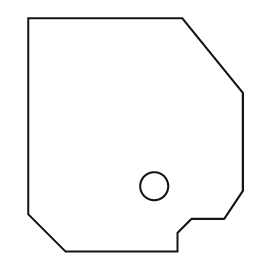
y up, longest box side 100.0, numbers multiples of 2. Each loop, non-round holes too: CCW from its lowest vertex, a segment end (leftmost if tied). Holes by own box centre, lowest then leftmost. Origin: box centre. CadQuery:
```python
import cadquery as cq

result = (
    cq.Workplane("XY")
    .moveTo(-30.0, -50.0)
    .lineTo(18.0, -50.0)
    .lineTo(18.0, -42.0)
    .lineTo(24.0, -36.0)
    .lineTo(38.0, -36.0)
    .lineTo(46.0, -24.0)
    .lineTo(46.0, 18.0)
    .lineTo(20.0, 50.0)
    .lineTo(-46.0, 50.0)
    .lineTo(-46.0, -34.0)
    .close()
    .moveTo(8.0, -22.0)
    .circle(6.0)
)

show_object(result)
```